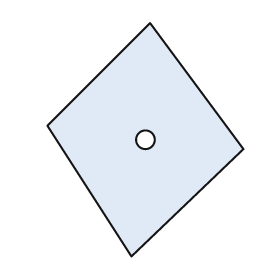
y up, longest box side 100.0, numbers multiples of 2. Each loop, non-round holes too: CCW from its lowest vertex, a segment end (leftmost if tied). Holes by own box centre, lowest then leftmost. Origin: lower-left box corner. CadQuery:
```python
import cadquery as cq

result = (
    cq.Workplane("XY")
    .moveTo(36.0, 0.0)
    .lineTo(84.0, 46.0)
    .lineTo(44.0, 100.0)
    .lineTo(0.0, 56.0)
    .close()
    .moveTo(42.0, 50.0)
    .circle(4.0)
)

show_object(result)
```